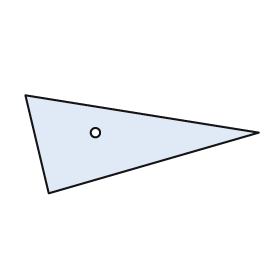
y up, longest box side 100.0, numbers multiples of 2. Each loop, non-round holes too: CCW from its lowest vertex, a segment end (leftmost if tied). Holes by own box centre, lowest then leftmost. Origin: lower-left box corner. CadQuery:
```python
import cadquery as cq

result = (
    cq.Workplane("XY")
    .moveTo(10.0, 0.0)
    .lineTo(100.0, 26.0)
    .lineTo(0.0, 42.0)
    .close()
    .moveTo(30.0, 26.0)
    .circle(2.0)
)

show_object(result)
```